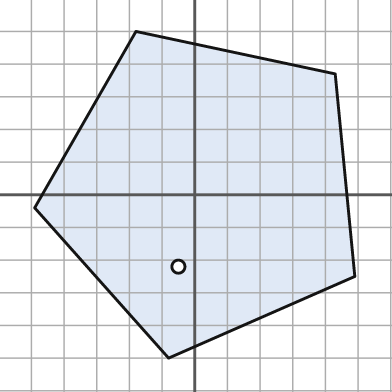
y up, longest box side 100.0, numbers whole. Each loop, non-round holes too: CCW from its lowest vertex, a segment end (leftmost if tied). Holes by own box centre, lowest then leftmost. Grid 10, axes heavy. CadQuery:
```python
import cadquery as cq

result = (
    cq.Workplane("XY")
    .moveTo(-8.0, -50.0)
    .lineTo(49.0, -25.0)
    .lineTo(43.0, 37.0)
    .lineTo(-18.0, 50.0)
    .lineTo(-49.0, -4.0)
    .close()
    .moveTo(-5.0, -22.0)
    .circle(2.0)
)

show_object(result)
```